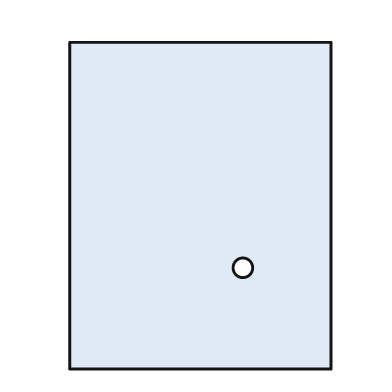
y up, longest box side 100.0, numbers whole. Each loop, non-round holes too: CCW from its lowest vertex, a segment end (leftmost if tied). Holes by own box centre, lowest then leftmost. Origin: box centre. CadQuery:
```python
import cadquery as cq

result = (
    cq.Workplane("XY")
    .moveTo(-40.0, -50.0)
    .lineTo(40.0, -50.0)
    .lineTo(40.0, 50.0)
    .lineTo(-40.0, 50.0)
    .close()
    .moveTo(13.0, -19.0)
    .circle(3.0)
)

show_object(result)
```